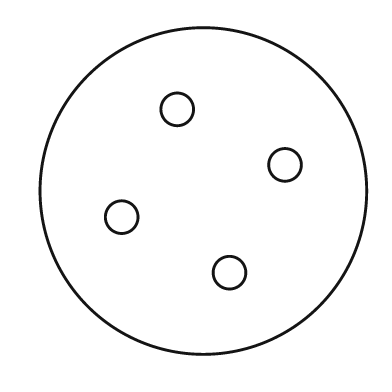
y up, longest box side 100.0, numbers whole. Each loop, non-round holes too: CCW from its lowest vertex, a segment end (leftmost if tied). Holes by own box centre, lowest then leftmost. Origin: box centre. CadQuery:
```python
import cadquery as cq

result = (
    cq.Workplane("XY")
    .moveTo(0.0, 0.0)
    .circle(50.0)
    .moveTo(8.0, -25.0)
    .circle(5.0)
    .moveTo(-25.0, -8.0)
    .circle(5.0)
    .moveTo(25.0, 8.0)
    .circle(5.0)
    .moveTo(-8.0, 25.0)
    .circle(5.0)
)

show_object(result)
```